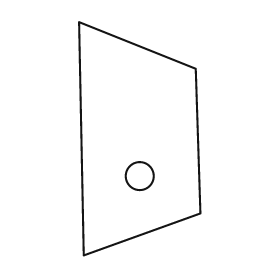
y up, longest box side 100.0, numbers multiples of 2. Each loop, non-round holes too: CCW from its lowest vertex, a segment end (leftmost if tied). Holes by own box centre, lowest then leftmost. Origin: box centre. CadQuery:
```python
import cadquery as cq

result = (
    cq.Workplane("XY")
    .moveTo(-24.0, -50.0)
    .lineTo(26.0, -32.0)
    .lineTo(24.0, 30.0)
    .lineTo(-26.0, 50.0)
    .close()
    .moveTo(0.0, -16.0)
    .circle(6.0)
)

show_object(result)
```